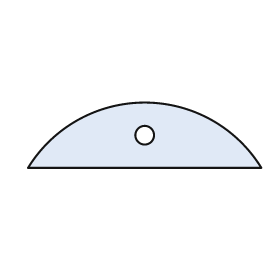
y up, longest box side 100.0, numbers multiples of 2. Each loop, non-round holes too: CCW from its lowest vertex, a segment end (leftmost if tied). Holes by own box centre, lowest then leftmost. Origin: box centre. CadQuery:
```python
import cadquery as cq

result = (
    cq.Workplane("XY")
    .moveTo(-50.0, -14.0)
    .lineTo(50.0, -14.0)
    .threePointArc((0.0, 14.0), (-50.0, -14.0))
    .close()
    .moveTo(0.0, 0.0)
    .circle(4.0)
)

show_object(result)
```